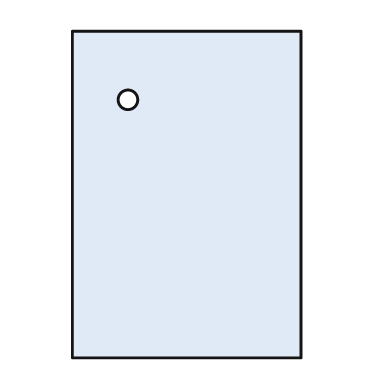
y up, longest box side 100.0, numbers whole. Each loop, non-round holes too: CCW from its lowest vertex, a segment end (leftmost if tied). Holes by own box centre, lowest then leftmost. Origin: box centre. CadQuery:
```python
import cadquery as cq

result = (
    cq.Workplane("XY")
    .moveTo(-35.0, -50.0)
    .lineTo(35.0, -50.0)
    .lineTo(35.0, 50.0)
    .lineTo(-35.0, 50.0)
    .close()
    .moveTo(-18.0, 29.0)
    .circle(3.0)
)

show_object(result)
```